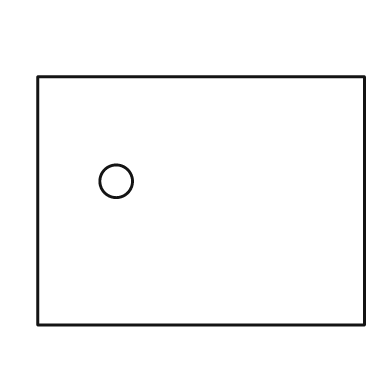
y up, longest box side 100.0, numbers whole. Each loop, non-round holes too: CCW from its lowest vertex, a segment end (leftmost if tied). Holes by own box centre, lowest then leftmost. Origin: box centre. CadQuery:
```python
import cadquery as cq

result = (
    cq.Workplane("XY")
    .moveTo(-50.0, -38.0)
    .lineTo(50.0, -38.0)
    .lineTo(50.0, 38.0)
    .lineTo(-50.0, 38.0)
    .close()
    .moveTo(-26.0, 6.0)
    .circle(5.0)
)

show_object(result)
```